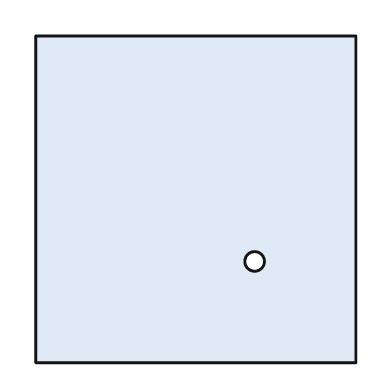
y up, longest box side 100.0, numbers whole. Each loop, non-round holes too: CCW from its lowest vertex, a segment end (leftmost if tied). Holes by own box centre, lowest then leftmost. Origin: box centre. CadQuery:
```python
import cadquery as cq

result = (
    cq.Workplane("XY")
    .moveTo(-49.0, -50.0)
    .lineTo(49.0, -50.0)
    .lineTo(49.0, 50.0)
    .lineTo(-49.0, 50.0)
    .close()
    .moveTo(18.0, -19.0)
    .circle(3.0)
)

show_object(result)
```